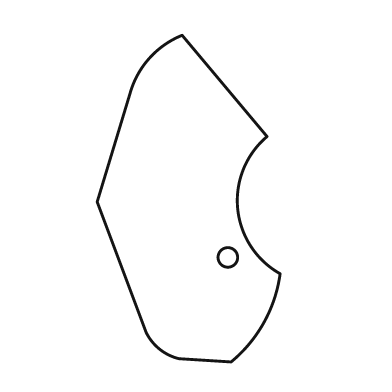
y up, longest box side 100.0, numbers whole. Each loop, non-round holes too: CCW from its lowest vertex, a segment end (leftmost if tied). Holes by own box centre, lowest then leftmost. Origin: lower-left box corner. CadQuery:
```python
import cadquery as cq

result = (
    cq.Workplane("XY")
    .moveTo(41.0, 0.0)
    .threePointArc((51.0, 12.0), (56.0, 27.0))
    .threePointArc((43.0, 47.0), (52.0, 69.0))
    .lineTo(26.0, 100.0)
    .threePointArc((16.0, 93.0), (10.0, 82.0))
    .lineTo(0.0, 49.0)
    .lineTo(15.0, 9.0)
    .threePointArc((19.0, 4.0), (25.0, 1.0))
    .close()
    .moveTo(40.0, 32.0)
    .circle(3.0)
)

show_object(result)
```